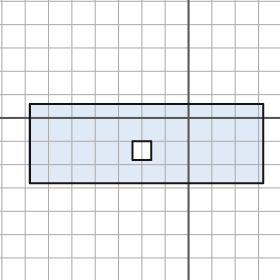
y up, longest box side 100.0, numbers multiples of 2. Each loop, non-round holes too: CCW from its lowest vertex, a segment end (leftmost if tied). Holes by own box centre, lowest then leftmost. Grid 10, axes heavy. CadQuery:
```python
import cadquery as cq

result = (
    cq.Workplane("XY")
    .moveTo(-68.0, -28.0)
    .lineTo(32.0, -28.0)
    .lineTo(32.0, 6.0)
    .lineTo(-68.0, 6.0)
    .close()
    .moveTo(-24.0, -18.0)
    .lineTo(-16.0, -18.0)
    .lineTo(-16.0, -10.0)
    .lineTo(-24.0, -10.0)
    .close()
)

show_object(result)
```